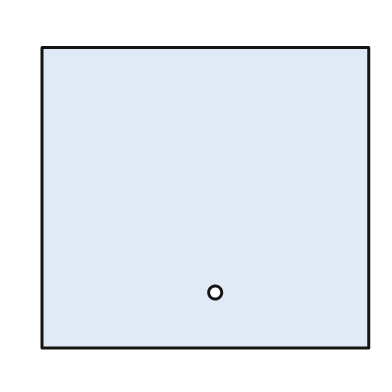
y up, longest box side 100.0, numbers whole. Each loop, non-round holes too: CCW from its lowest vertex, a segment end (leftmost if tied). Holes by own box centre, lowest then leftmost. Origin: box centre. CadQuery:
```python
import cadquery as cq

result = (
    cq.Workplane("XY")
    .moveTo(-50.0, -46.0)
    .lineTo(50.0, -46.0)
    .lineTo(50.0, 46.0)
    .lineTo(-50.0, 46.0)
    .close()
    .moveTo(3.0, -29.0)
    .circle(2.0)
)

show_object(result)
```